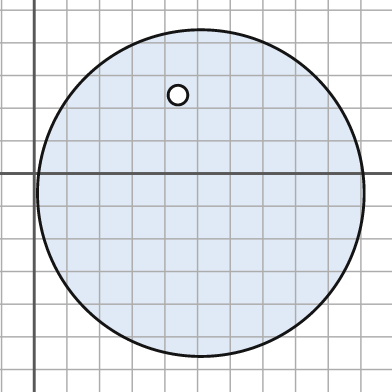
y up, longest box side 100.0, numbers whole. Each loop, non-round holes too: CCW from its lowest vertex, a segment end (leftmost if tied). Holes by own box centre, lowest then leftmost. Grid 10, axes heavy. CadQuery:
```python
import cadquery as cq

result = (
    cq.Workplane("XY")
    .moveTo(51.0, -6.0)
    .circle(50.0)
    .moveTo(44.0, 24.0)
    .circle(3.0)
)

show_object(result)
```